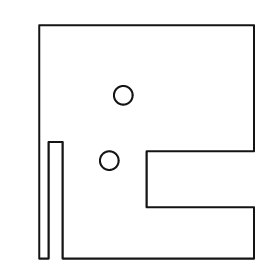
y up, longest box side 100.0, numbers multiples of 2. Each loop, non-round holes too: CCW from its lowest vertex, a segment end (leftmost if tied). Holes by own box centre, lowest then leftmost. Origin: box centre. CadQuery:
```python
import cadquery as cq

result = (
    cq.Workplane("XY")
    .moveTo(-46.0, -50.0)
    .lineTo(-42.0, -50.0)
    .lineTo(-42.0, 0.0)
    .lineTo(-36.0, 0.0)
    .lineTo(-36.0, -50.0)
    .lineTo(46.0, -50.0)
    .lineTo(46.0, -28.0)
    .lineTo(0.0, -28.0)
    .lineTo(0.0, -4.0)
    .lineTo(46.0, -4.0)
    .lineTo(46.0, 50.0)
    .lineTo(-46.0, 50.0)
    .close()
    .moveTo(-16.0, -8.0)
    .circle(4.0)
    .moveTo(-10.0, 20.0)
    .circle(4.0)
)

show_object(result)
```